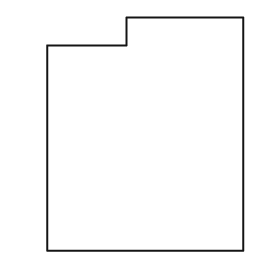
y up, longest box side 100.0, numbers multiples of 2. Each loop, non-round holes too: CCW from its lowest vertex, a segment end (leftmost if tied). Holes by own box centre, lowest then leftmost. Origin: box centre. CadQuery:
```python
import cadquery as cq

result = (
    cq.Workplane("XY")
    .moveTo(-42.0, -50.0)
    .lineTo(42.0, -50.0)
    .lineTo(42.0, 50.0)
    .lineTo(-8.0, 50.0)
    .lineTo(-8.0, 38.0)
    .lineTo(-42.0, 38.0)
    .close()
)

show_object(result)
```